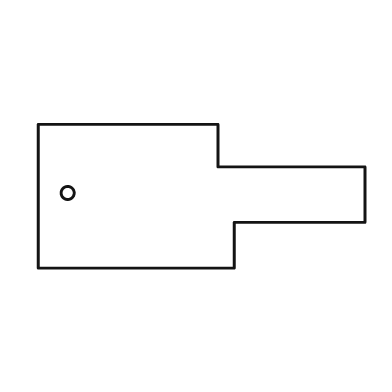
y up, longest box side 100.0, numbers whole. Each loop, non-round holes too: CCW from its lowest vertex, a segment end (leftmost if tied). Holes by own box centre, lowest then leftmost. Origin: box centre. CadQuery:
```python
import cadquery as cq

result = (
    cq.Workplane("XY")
    .moveTo(-50.0, -22.0)
    .lineTo(10.0, -22.0)
    .lineTo(10.0, -8.0)
    .lineTo(50.0, -8.0)
    .lineTo(50.0, 9.0)
    .lineTo(5.0, 9.0)
    .lineTo(5.0, 22.0)
    .lineTo(-50.0, 22.0)
    .close()
    .moveTo(-41.0, 1.0)
    .circle(2.0)
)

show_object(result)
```